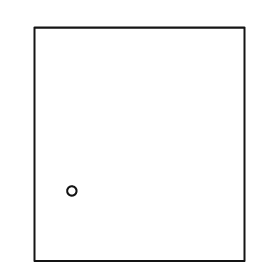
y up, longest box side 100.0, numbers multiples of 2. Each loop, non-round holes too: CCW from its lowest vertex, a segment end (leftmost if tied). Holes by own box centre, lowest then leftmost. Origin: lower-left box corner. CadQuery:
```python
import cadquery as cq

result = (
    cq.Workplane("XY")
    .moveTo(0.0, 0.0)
    .lineTo(90.0, 0.0)
    .lineTo(90.0, 100.0)
    .lineTo(0.0, 100.0)
    .close()
    .moveTo(16.0, 30.0)
    .circle(2.0)
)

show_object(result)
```